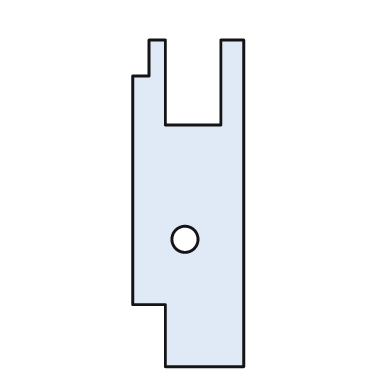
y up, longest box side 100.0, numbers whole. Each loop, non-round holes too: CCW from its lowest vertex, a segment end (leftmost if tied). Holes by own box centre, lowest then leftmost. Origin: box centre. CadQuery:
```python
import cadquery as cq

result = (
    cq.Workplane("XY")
    .moveTo(-7.0, -50.0)
    .lineTo(17.0, -50.0)
    .lineTo(17.0, 50.0)
    .lineTo(10.0, 50.0)
    .lineTo(10.0, 24.0)
    .lineTo(-7.0, 24.0)
    .lineTo(-7.0, 50.0)
    .lineTo(-12.0, 50.0)
    .lineTo(-12.0, 39.0)
    .lineTo(-17.0, 39.0)
    .lineTo(-17.0, -31.0)
    .lineTo(-7.0, -31.0)
    .close()
    .moveTo(-1.0, -11.0)
    .circle(4.0)
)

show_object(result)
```